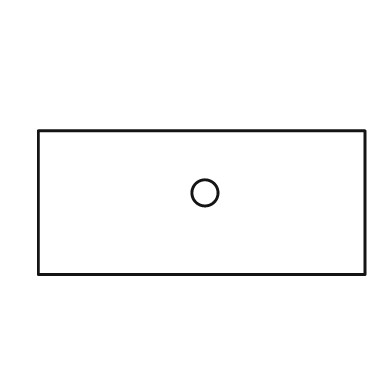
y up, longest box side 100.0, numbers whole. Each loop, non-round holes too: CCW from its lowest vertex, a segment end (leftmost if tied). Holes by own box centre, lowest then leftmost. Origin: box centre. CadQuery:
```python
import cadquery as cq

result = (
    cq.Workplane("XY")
    .moveTo(-50.0, -22.0)
    .lineTo(50.0, -22.0)
    .lineTo(50.0, 22.0)
    .lineTo(-50.0, 22.0)
    .close()
    .moveTo(1.0, 3.0)
    .circle(4.0)
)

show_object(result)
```